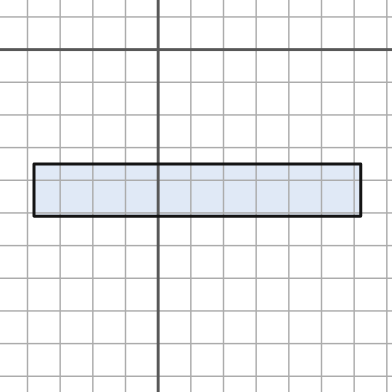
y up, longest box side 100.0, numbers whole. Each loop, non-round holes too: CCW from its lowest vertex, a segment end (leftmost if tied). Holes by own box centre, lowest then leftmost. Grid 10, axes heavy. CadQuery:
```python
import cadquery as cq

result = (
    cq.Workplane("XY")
    .moveTo(-38.0, -51.0)
    .lineTo(62.0, -51.0)
    .lineTo(62.0, -35.0)
    .lineTo(-38.0, -35.0)
    .close()
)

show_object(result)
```